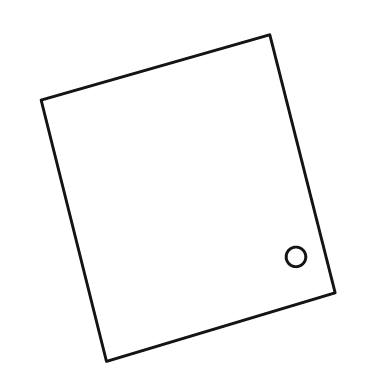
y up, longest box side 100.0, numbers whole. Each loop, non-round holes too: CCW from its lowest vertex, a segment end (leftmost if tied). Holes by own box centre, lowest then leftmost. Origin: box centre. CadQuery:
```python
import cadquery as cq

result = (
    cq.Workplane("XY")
    .moveTo(-25.0, -50.0)
    .lineTo(45.0, -29.0)
    .lineTo(25.0, 50.0)
    .lineTo(-45.0, 30.0)
    .close()
    .moveTo(33.0, -18.0)
    .circle(3.0)
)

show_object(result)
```